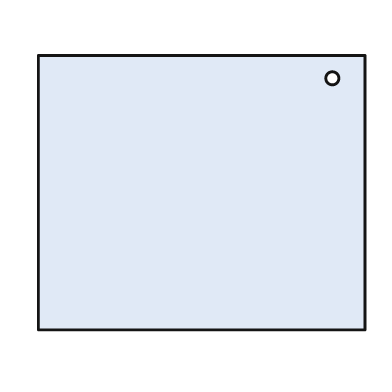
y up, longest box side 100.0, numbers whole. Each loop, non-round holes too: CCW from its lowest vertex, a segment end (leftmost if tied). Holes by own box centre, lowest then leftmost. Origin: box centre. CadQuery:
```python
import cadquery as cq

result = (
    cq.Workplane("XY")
    .moveTo(-50.0, -42.0)
    .lineTo(50.0, -42.0)
    .lineTo(50.0, 42.0)
    .lineTo(-50.0, 42.0)
    .close()
    .moveTo(40.0, 35.0)
    .circle(2.0)
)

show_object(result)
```